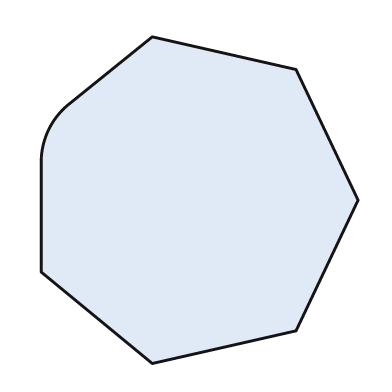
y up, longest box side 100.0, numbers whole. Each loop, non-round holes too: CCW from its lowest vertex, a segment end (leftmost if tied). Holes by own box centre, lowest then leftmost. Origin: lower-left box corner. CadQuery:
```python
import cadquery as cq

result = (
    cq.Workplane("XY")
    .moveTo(34.0, 0.0)
    .lineTo(78.0, 10.0)
    .lineTo(97.0, 50.0)
    .lineTo(78.0, 90.0)
    .lineTo(34.0, 100.0)
    .lineTo(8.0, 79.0)
    .threePointArc((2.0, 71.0), (0.0, 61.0))
    .lineTo(0.0, 28.0)
    .close()
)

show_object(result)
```